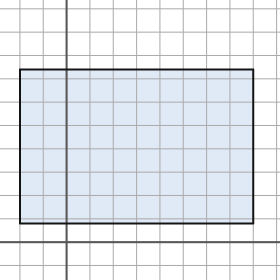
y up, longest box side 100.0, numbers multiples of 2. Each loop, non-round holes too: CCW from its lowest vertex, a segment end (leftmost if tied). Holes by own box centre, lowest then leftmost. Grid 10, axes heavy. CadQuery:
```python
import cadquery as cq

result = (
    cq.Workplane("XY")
    .moveTo(-20.0, 8.0)
    .lineTo(80.0, 8.0)
    .lineTo(80.0, 74.0)
    .lineTo(-20.0, 74.0)
    .close()
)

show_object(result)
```